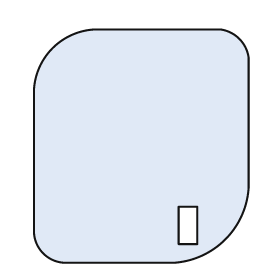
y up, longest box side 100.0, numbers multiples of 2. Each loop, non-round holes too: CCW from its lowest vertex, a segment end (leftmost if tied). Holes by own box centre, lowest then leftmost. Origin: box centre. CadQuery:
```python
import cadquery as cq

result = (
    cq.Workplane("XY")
    .moveTo(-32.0, -50.0)
    .lineTo(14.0, -50.0)
    .threePointArc((36.0, -40.0), (46.0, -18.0))
    .lineTo(46.0, 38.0)
    .threePointArc((42.0, 46.0), (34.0, 50.0))
    .lineTo(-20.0, 50.0)
    .threePointArc((-38.0, 42.0), (-46.0, 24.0))
    .lineTo(-46.0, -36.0)
    .threePointArc((-42.0, -46.0), (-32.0, -50.0))
    .close()
    .moveTo(16.0, -42.0)
    .lineTo(24.0, -42.0)
    .lineTo(24.0, -26.0)
    .lineTo(16.0, -26.0)
    .close()
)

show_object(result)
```